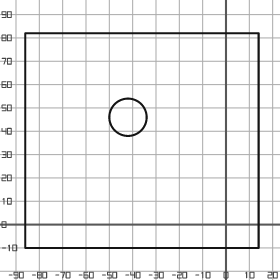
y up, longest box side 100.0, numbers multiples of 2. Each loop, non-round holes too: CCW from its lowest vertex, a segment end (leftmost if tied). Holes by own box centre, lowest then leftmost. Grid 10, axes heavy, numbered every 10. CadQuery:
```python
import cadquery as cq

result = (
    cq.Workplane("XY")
    .moveTo(-86.0, -10.0)
    .lineTo(14.0, -10.0)
    .lineTo(14.0, 82.0)
    .lineTo(-86.0, 82.0)
    .close()
    .moveTo(-42.0, 46.0)
    .circle(8.0)
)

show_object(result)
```